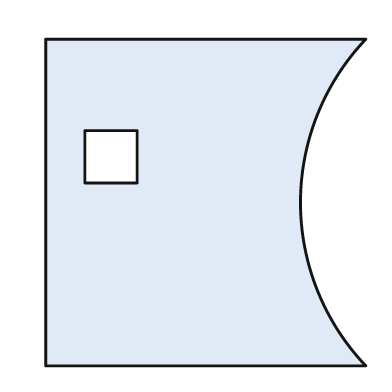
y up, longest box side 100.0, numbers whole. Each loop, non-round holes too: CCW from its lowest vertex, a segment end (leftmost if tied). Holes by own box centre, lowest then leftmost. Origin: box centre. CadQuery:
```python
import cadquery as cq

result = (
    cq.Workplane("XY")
    .moveTo(-49.0, -50.0)
    .lineTo(49.0, -50.0)
    .threePointArc((29.0, 0.0), (49.0, 50.0))
    .lineTo(-49.0, 50.0)
    .close()
    .moveTo(-37.0, 6.0)
    .lineTo(-21.0, 6.0)
    .lineTo(-21.0, 22.0)
    .lineTo(-37.0, 22.0)
    .close()
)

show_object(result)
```